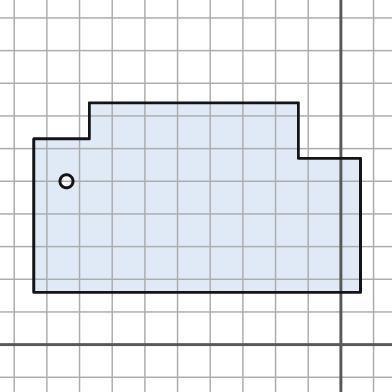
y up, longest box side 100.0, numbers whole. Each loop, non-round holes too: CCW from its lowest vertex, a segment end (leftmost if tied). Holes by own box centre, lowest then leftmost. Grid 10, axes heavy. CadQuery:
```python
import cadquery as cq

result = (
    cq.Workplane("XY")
    .moveTo(-94.0, 16.0)
    .lineTo(6.0, 16.0)
    .lineTo(6.0, 57.0)
    .lineTo(-13.0, 57.0)
    .lineTo(-13.0, 74.0)
    .lineTo(-77.0, 74.0)
    .lineTo(-77.0, 63.0)
    .lineTo(-94.0, 63.0)
    .close()
    .moveTo(-84.0, 50.0)
    .circle(2.0)
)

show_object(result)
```